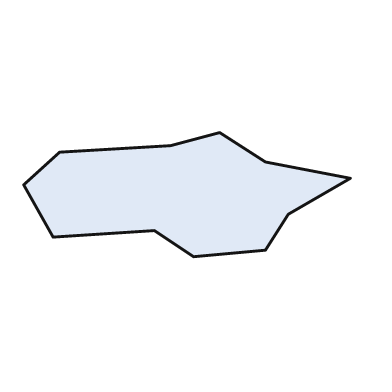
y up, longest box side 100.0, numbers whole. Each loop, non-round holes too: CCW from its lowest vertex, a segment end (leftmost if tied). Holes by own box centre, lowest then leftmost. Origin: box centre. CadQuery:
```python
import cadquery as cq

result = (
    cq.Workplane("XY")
    .moveTo(2.0, -19.0)
    .lineTo(24.0, -17.0)
    .lineTo(31.0, -6.0)
    .lineTo(50.0, 5.0)
    .lineTo(24.0, 10.0)
    .lineTo(10.0, 19.0)
    .lineTo(-5.0, 15.0)
    .lineTo(-39.0, 13.0)
    .lineTo(-50.0, 3.0)
    .lineTo(-41.0, -13.0)
    .lineTo(-10.0, -11.0)
    .close()
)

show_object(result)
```